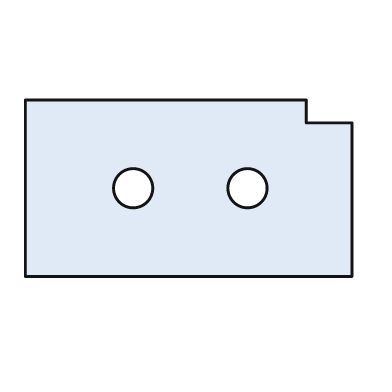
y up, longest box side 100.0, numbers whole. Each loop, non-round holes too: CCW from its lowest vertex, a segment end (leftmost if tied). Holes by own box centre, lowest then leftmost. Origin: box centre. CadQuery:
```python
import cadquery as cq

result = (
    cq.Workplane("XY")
    .moveTo(-50.0, -27.0)
    .lineTo(50.0, -27.0)
    .lineTo(50.0, 20.0)
    .lineTo(36.0, 20.0)
    .lineTo(36.0, 27.0)
    .lineTo(-50.0, 27.0)
    .close()
    .moveTo(-17.0, 0.0)
    .circle(6.0)
    .moveTo(18.0, 0.0)
    .circle(6.0)
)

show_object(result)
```